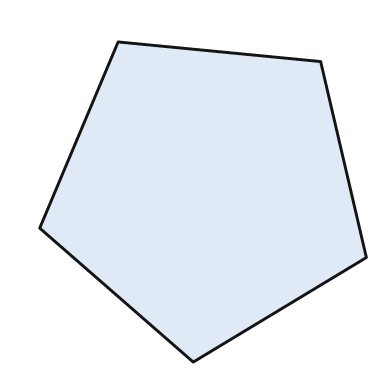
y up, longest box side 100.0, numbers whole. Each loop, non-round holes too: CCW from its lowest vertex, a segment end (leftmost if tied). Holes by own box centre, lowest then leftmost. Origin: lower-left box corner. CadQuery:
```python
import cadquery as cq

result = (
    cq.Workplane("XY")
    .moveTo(47.0, 0.0)
    .lineTo(100.0, 32.0)
    .lineTo(86.0, 92.0)
    .lineTo(24.0, 98.0)
    .lineTo(0.0, 41.0)
    .close()
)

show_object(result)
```